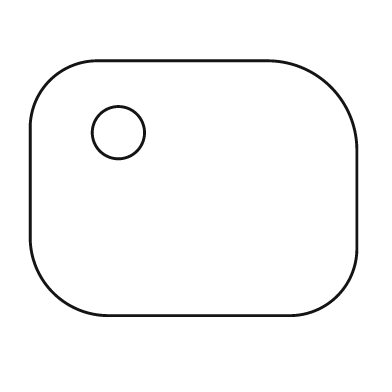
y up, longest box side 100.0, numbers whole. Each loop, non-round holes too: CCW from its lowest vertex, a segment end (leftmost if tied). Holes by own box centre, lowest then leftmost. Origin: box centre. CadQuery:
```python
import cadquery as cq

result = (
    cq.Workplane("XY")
    .moveTo(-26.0, -39.0)
    .lineTo(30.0, -39.0)
    .threePointArc((44.0, -33.0), (50.0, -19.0))
    .lineTo(50.0, 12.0)
    .threePointArc((42.0, 31.0), (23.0, 39.0))
    .lineTo(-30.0, 39.0)
    .threePointArc((-44.0, 33.0), (-50.0, 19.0))
    .lineTo(-50.0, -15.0)
    .threePointArc((-43.0, -32.0), (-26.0, -39.0))
    .close()
    .moveTo(-23.0, 17.0)
    .circle(8.0)
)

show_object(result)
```